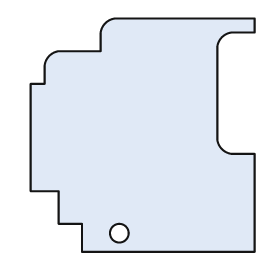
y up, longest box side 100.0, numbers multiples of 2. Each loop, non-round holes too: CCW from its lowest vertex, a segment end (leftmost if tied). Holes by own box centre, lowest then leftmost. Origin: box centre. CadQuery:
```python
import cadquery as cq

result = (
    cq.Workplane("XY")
    .moveTo(-26.0, -50.0)
    .lineTo(48.0, -50.0)
    .lineTo(48.0, -8.0)
    .lineTo(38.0, -8.0)
    .threePointArc((34.0, -6.0), (32.0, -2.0))
    .lineTo(32.0, 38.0)
    .threePointArc((34.0, 42.0), (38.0, 44.0))
    .lineTo(48.0, 44.0)
    .lineTo(48.0, 50.0)
    .lineTo(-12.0, 50.0)
    .threePointArc((-16.0, 48.0), (-18.0, 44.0))
    .lineTo(-18.0, 36.0)
    .lineTo(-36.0, 36.0)
    .threePointArc((-40.0, 34.0), (-42.0, 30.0))
    .lineTo(-42.0, 22.0)
    .lineTo(-48.0, 22.0)
    .lineTo(-48.0, -24.0)
    .lineTo(-36.0, -24.0)
    .lineTo(-36.0, -38.0)
    .lineTo(-26.0, -38.0)
    .close()
    .moveTo(-10.0, -42.0)
    .circle(4.0)
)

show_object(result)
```